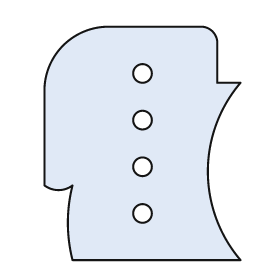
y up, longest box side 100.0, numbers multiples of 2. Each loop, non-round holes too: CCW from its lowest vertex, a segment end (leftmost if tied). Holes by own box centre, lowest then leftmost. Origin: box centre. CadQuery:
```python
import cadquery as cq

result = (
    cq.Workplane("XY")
    .moveTo(-30.0, -50.0)
    .lineTo(42.0, -50.0)
    .threePointArc((28.0, -12.0), (42.0, 26.0))
    .lineTo(32.0, 26.0)
    .lineTo(32.0, 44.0)
    .threePointArc((30.0, 48.0), (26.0, 50.0))
    .lineTo(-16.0, 50.0)
    .threePointArc((-34.0, 42.0), (-42.0, 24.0))
    .lineTo(-42.0, -18.0)
    .threePointArc((-36.0, -20.0), (-30.0, -18.0))
    .threePointArc((-32.0, -34.0), (-30.0, -50.0))
    .close()
    .moveTo(0.0, -30.0)
    .circle(4.0)
    .moveTo(0.0, -10.0)
    .circle(4.0)
    .moveTo(0.0, 10.0)
    .circle(4.0)
    .moveTo(0.0, 30.0)
    .circle(4.0)
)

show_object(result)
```